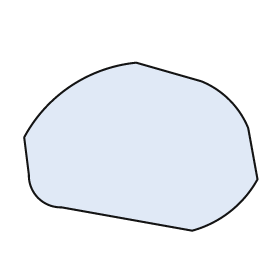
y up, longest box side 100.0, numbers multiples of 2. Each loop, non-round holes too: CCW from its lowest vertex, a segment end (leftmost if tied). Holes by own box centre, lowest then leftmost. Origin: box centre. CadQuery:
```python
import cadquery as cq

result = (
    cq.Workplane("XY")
    .moveTo(22.0, -36.0)
    .threePointArc((38.0, -28.0), (50.0, -14.0))
    .lineTo(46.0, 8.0)
    .threePointArc((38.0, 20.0), (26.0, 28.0))
    .lineTo(-2.0, 36.0)
    .threePointArc((-30.0, 26.0), (-50.0, 4.0))
    .lineTo(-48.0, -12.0)
    .threePointArc((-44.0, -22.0), (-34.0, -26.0))
    .close()
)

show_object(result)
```